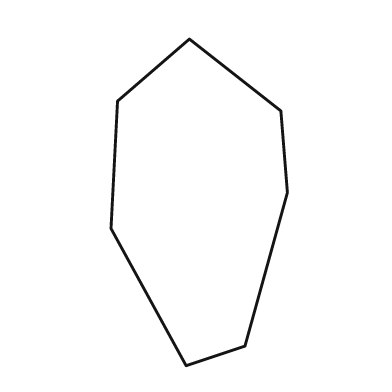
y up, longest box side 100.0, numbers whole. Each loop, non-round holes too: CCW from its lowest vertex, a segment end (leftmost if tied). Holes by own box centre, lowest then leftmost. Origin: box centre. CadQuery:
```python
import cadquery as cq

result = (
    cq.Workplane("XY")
    .moveTo(-4.0, -50.0)
    .lineTo(14.0, -44.0)
    .lineTo(27.0, 3.0)
    .lineTo(25.0, 28.0)
    .lineTo(-3.0, 50.0)
    .lineTo(-25.0, 31.0)
    .lineTo(-27.0, -8.0)
    .close()
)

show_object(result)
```